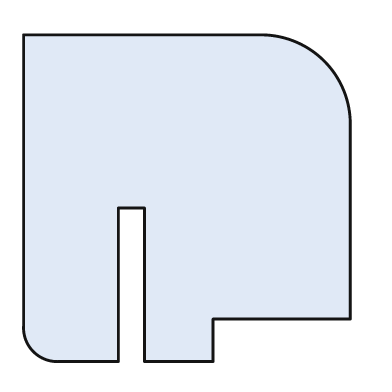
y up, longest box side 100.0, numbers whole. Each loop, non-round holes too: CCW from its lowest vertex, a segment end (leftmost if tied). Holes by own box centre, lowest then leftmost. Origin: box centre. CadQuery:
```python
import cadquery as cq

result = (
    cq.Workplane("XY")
    .moveTo(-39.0, -50.0)
    .lineTo(-21.0, -50.0)
    .lineTo(-21.0, -3.0)
    .lineTo(-13.0, -3.0)
    .lineTo(-13.0, -50.0)
    .lineTo(8.0, -50.0)
    .lineTo(8.0, -37.0)
    .lineTo(50.0, -37.0)
    .lineTo(50.0, 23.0)
    .threePointArc((42.0, 42.0), (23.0, 50.0))
    .lineTo(-50.0, 50.0)
    .lineTo(-50.0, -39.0)
    .threePointArc((-47.0, -47.0), (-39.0, -50.0))
    .close()
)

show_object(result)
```